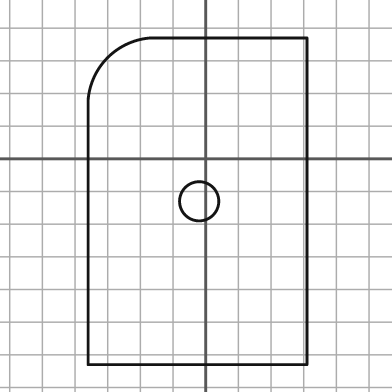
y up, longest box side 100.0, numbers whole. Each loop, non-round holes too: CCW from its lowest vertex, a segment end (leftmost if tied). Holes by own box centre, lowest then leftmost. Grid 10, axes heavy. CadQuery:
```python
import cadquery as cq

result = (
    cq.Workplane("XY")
    .moveTo(-36.0, -63.0)
    .lineTo(31.0, -63.0)
    .lineTo(31.0, 37.0)
    .lineTo(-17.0, 37.0)
    .threePointArc((-30.0, 31.0), (-36.0, 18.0))
    .close()
    .moveTo(-2.0, -13.0)
    .circle(6.0)
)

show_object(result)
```